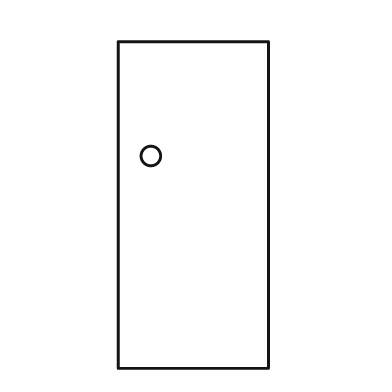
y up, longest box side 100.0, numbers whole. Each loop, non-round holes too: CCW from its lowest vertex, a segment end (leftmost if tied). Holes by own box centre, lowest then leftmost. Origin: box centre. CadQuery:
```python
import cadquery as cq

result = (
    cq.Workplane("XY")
    .moveTo(-23.0, -50.0)
    .lineTo(23.0, -50.0)
    .lineTo(23.0, 50.0)
    .lineTo(-23.0, 50.0)
    .close()
    .moveTo(-13.0, 15.0)
    .circle(3.0)
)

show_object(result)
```